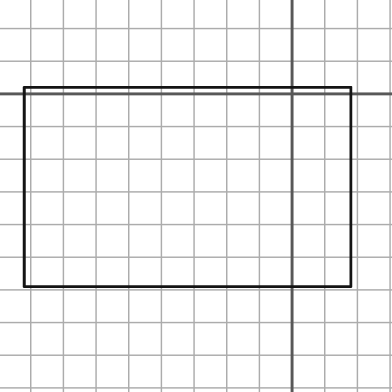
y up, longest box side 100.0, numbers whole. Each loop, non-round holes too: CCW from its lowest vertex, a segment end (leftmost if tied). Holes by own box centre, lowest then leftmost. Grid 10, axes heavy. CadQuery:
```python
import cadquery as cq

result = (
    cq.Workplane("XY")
    .moveTo(-82.0, -59.0)
    .lineTo(18.0, -59.0)
    .lineTo(18.0, 2.0)
    .lineTo(-82.0, 2.0)
    .close()
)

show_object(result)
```